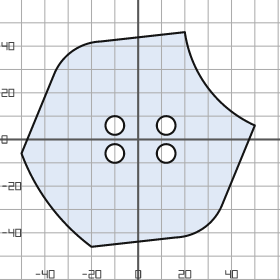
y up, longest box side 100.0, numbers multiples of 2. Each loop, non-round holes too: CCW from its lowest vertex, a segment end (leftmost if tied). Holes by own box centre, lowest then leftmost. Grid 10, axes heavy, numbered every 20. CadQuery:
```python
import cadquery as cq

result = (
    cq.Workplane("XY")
    .moveTo(-20.0, -46.0)
    .lineTo(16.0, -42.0)
    .threePointArc((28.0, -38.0), (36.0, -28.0))
    .lineTo(50.0, 6.0)
    .threePointArc((30.0, 22.0), (20.0, 46.0))
    .lineTo(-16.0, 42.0)
    .threePointArc((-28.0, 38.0), (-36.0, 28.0))
    .lineTo(-50.0, -6.0)
    .threePointArc((-38.0, -28.0), (-20.0, -46.0))
    .close()
    .moveTo(-10.0, -6.0)
    .circle(4.0)
    .moveTo(12.0, -6.0)
    .circle(4.0)
    .moveTo(-10.0, 6.0)
    .circle(4.0)
    .moveTo(12.0, 6.0)
    .circle(4.0)
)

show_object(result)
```